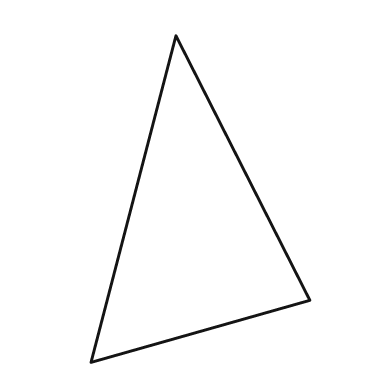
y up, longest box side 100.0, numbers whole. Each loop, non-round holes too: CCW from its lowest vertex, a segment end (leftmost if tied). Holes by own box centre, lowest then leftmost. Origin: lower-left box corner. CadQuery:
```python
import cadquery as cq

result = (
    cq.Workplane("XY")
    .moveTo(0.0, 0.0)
    .lineTo(67.0, 19.0)
    .lineTo(26.0, 100.0)
    .close()
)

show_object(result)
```